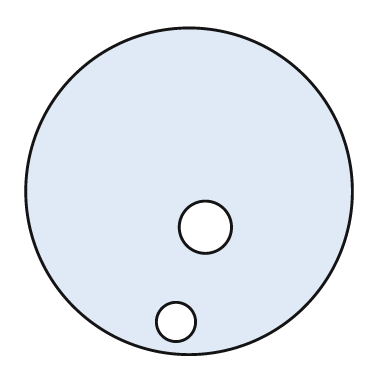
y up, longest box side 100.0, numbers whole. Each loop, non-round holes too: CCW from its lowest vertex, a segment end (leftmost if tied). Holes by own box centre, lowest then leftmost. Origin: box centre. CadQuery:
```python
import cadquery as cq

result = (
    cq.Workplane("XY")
    .moveTo(0.0, 0.0)
    .circle(50.0)
    .moveTo(-4.0, -40.0)
    .circle(6.0)
    .moveTo(5.0, -11.0)
    .circle(8.0)
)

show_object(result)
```